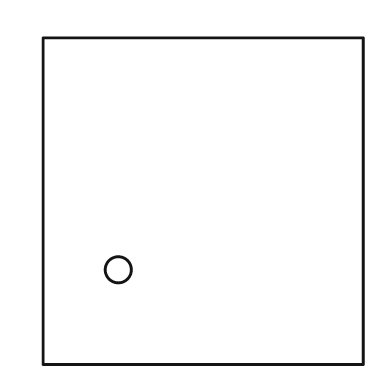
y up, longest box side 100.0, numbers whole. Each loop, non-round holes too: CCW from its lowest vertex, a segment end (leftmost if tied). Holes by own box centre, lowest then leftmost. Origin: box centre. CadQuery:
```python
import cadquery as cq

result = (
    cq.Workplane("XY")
    .moveTo(-49.0, -50.0)
    .lineTo(49.0, -50.0)
    .lineTo(49.0, 50.0)
    .lineTo(-49.0, 50.0)
    .close()
    .moveTo(-26.0, -21.0)
    .circle(4.0)
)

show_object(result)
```